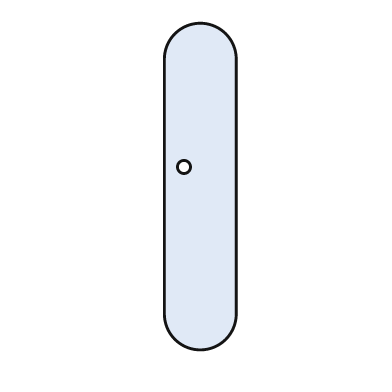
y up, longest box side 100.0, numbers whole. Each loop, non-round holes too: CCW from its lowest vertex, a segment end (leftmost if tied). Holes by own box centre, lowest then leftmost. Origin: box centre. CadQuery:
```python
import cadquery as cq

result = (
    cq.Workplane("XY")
    .moveTo(-11.0, -39.0)
    .threePointArc((0.0, -50.0), (11.0, -39.0))
    .lineTo(11.0, 39.0)
    .threePointArc((0.0, 50.0), (-11.0, 39.0))
    .close()
    .moveTo(-5.0, 6.0)
    .circle(2.0)
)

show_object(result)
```